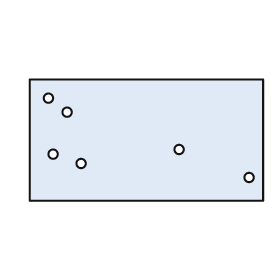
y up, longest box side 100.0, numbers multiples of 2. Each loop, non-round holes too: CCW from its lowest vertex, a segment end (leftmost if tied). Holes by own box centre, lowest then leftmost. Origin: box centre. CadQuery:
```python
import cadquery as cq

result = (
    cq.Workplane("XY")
    .moveTo(-50.0, -26.0)
    .lineTo(50.0, -26.0)
    .lineTo(50.0, 26.0)
    .lineTo(-50.0, 26.0)
    .close()
    .moveTo(44.0, -16.0)
    .circle(2.0)
    .moveTo(-28.0, -10.0)
    .circle(2.0)
    .moveTo(-40.0, -6.0)
    .circle(2.0)
    .moveTo(14.0, -4.0)
    .circle(2.0)
    .moveTo(-34.0, 12.0)
    .circle(2.0)
    .moveTo(-42.0, 18.0)
    .circle(2.0)
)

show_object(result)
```